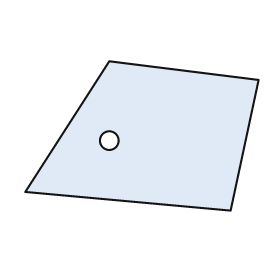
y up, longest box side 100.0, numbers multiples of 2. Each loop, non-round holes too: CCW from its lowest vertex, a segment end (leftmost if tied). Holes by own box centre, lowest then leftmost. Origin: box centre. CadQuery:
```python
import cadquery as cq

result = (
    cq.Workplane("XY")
    .moveTo(38.0, -32.0)
    .lineTo(50.0, 24.0)
    .lineTo(-14.0, 32.0)
    .lineTo(-50.0, -24.0)
    .close()
    .moveTo(-14.0, -2.0)
    .circle(4.0)
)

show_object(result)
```